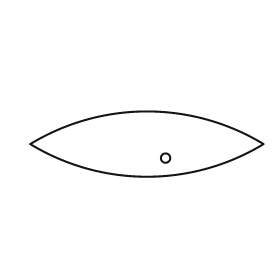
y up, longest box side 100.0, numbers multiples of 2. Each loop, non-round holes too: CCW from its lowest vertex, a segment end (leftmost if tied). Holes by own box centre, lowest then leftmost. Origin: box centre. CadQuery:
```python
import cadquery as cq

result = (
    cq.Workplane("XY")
    .moveTo(-50.0, 0.0)
    .threePointArc((0.0, -14.0), (50.0, 0.0))
    .threePointArc((0.0, 14.0), (-50.0, 0.0))
    .close()
    .moveTo(8.0, -6.0)
    .circle(2.0)
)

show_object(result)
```